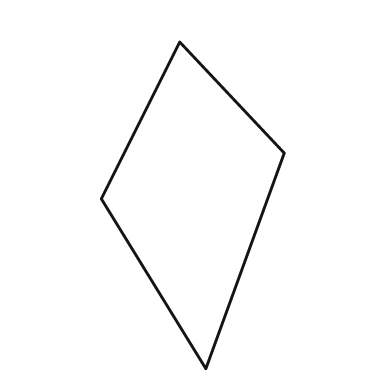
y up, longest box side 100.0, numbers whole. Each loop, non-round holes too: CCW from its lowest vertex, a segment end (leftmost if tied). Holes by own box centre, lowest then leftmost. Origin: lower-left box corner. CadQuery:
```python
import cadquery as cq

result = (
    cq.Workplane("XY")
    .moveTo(32.0, 0.0)
    .lineTo(56.0, 66.0)
    .lineTo(24.0, 100.0)
    .lineTo(0.0, 52.0)
    .close()
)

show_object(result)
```